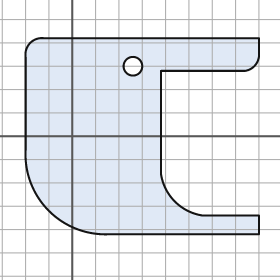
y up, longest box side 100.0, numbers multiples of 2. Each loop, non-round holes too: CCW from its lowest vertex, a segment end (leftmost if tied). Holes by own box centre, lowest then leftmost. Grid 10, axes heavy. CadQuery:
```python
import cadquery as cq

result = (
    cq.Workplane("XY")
    .moveTo(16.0, -42.0)
    .lineTo(80.0, -42.0)
    .lineTo(80.0, -34.0)
    .lineTo(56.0, -34.0)
    .threePointArc((44.0, -28.0), (38.0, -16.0))
    .lineTo(38.0, 28.0)
    .lineTo(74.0, 28.0)
    .threePointArc((78.0, 30.0), (80.0, 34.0))
    .lineTo(80.0, 42.0)
    .lineTo(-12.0, 42.0)
    .threePointArc((-18.0, 40.0), (-20.0, 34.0))
    .lineTo(-20.0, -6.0)
    .threePointArc((-10.0, -32.0), (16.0, -42.0))
    .close()
    .moveTo(26.0, 30.0)
    .circle(4.0)
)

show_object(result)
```